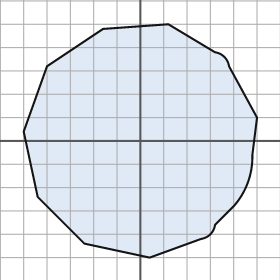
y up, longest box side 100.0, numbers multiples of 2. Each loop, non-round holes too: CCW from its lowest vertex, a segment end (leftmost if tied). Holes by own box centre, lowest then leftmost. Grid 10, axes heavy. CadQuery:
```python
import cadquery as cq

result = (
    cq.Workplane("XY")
    .moveTo(4.0, -50.0)
    .lineTo(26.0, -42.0)
    .threePointArc((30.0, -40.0), (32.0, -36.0))
    .lineTo(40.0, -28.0)
    .threePointArc((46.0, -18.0), (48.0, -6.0))
    .lineTo(50.0, 10.0)
    .lineTo(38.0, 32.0)
    .threePointArc((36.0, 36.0), (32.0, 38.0))
    .lineTo(12.0, 50.0)
    .lineTo(-16.0, 48.0)
    .lineTo(-40.0, 32.0)
    .lineTo(-50.0, 4.0)
    .lineTo(-44.0, -24.0)
    .lineTo(-24.0, -44.0)
    .close()
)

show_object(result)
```